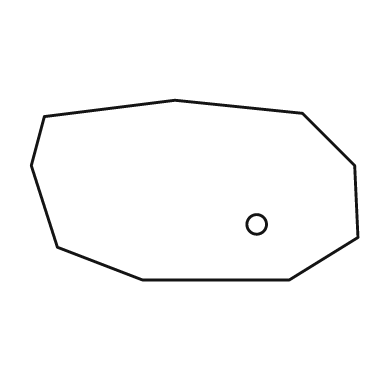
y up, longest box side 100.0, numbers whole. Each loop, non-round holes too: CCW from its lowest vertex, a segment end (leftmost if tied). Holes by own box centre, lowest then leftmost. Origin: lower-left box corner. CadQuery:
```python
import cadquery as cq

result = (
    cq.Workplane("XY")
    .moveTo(34.0, 0.0)
    .lineTo(79.0, 0.0)
    .lineTo(100.0, 13.0)
    .lineTo(99.0, 35.0)
    .lineTo(83.0, 51.0)
    .lineTo(44.0, 55.0)
    .lineTo(4.0, 50.0)
    .lineTo(0.0, 35.0)
    .lineTo(8.0, 10.0)
    .close()
    .moveTo(69.0, 17.0)
    .circle(3.0)
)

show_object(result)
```